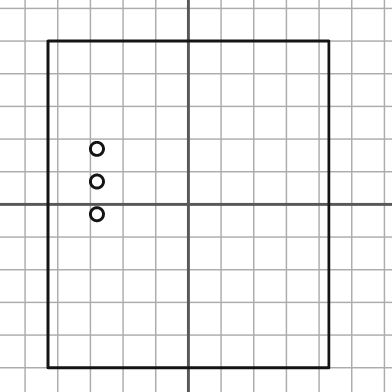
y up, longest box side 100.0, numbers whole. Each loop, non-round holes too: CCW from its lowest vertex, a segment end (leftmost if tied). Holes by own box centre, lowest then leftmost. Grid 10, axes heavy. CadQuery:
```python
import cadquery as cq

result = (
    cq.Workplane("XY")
    .moveTo(-43.0, -50.0)
    .lineTo(43.0, -50.0)
    .lineTo(43.0, 50.0)
    .lineTo(-43.0, 50.0)
    .close()
    .moveTo(-28.0, -3.0)
    .circle(2.0)
    .moveTo(-28.0, 7.0)
    .circle(2.0)
    .moveTo(-28.0, 17.0)
    .circle(2.0)
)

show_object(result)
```